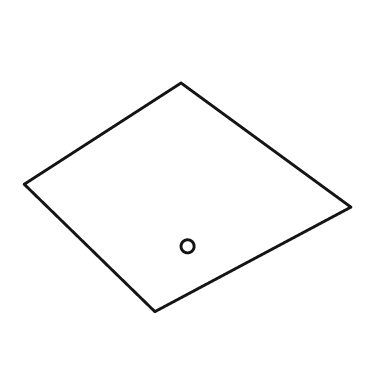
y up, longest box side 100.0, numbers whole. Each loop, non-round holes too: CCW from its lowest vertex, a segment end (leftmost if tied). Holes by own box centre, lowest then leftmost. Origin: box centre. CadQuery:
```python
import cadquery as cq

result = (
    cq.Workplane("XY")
    .moveTo(-10.0, -35.0)
    .lineTo(50.0, -3.0)
    .lineTo(-2.0, 35.0)
    .lineTo(-50.0, 4.0)
    .close()
    .moveTo(0.0, -15.0)
    .circle(2.0)
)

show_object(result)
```